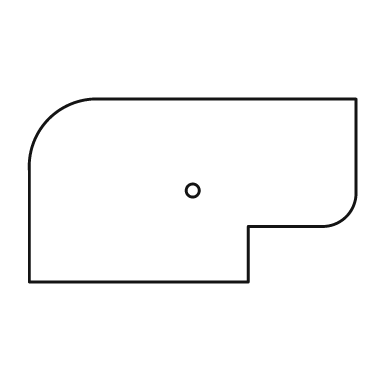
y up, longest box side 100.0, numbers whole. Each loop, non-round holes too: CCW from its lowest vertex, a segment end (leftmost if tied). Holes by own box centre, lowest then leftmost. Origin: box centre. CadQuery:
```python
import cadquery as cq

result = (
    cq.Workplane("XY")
    .moveTo(-50.0, -28.0)
    .lineTo(17.0, -28.0)
    .lineTo(17.0, -11.0)
    .lineTo(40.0, -11.0)
    .threePointArc((47.0, -8.0), (50.0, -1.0))
    .lineTo(50.0, 28.0)
    .lineTo(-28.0, 28.0)
    .threePointArc((-44.0, 22.0), (-50.0, 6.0))
    .close()
    .moveTo(0.0, 0.0)
    .circle(2.0)
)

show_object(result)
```